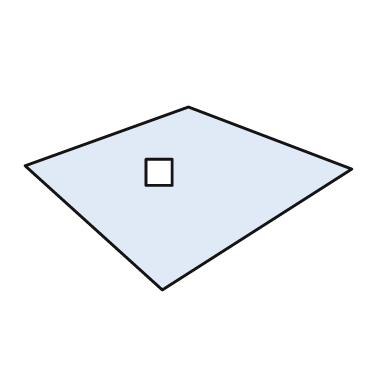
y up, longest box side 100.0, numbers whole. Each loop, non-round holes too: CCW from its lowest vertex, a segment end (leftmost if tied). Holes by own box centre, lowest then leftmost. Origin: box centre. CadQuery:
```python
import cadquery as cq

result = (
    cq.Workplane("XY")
    .moveTo(-8.0, -28.0)
    .lineTo(50.0, 9.0)
    .lineTo(0.0, 28.0)
    .lineTo(-50.0, 10.0)
    .close()
    .moveTo(-13.0, 4.0)
    .lineTo(-5.0, 4.0)
    .lineTo(-5.0, 12.0)
    .lineTo(-13.0, 12.0)
    .close()
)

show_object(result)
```